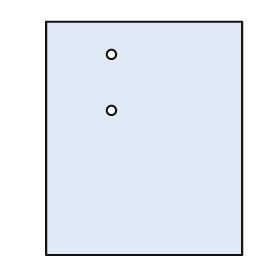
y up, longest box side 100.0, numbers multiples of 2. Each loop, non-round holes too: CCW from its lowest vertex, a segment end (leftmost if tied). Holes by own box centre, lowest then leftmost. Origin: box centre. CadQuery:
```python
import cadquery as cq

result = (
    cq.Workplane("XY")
    .moveTo(-42.0, -50.0)
    .lineTo(42.0, -50.0)
    .lineTo(42.0, 50.0)
    .lineTo(-42.0, 50.0)
    .close()
    .moveTo(-14.0, 12.0)
    .circle(2.0)
    .moveTo(-14.0, 36.0)
    .circle(2.0)
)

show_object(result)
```